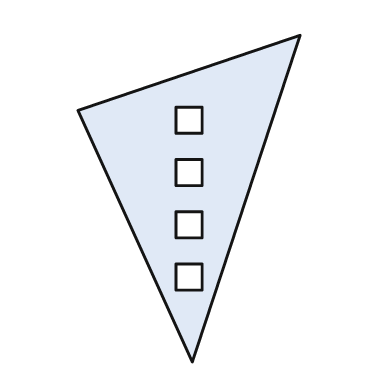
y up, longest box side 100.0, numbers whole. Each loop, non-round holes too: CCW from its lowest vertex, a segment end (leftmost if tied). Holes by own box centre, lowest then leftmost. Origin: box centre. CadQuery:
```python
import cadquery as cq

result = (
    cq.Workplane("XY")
    .moveTo(1.0, -50.0)
    .lineTo(34.0, 50.0)
    .lineTo(-34.0, 27.0)
    .close()
    .moveTo(-4.0, -28.0)
    .lineTo(4.0, -28.0)
    .lineTo(4.0, -20.0)
    .lineTo(-4.0, -20.0)
    .close()
    .moveTo(-4.0, -12.0)
    .lineTo(4.0, -12.0)
    .lineTo(4.0, -4.0)
    .lineTo(-4.0, -4.0)
    .close()
    .moveTo(-4.0, 4.0)
    .lineTo(4.0, 4.0)
    .lineTo(4.0, 12.0)
    .lineTo(-4.0, 12.0)
    .close()
    .moveTo(-4.0, 20.0)
    .lineTo(4.0, 20.0)
    .lineTo(4.0, 28.0)
    .lineTo(-4.0, 28.0)
    .close()
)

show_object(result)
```